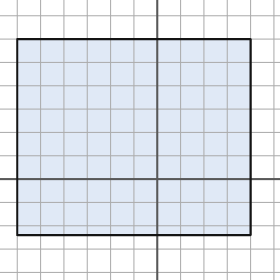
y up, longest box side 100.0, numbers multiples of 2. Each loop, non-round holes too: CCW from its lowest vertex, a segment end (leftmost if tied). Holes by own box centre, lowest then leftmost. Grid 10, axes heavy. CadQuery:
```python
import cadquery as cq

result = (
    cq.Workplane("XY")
    .moveTo(-60.0, -24.0)
    .lineTo(40.0, -24.0)
    .lineTo(40.0, 60.0)
    .lineTo(-60.0, 60.0)
    .close()
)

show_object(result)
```